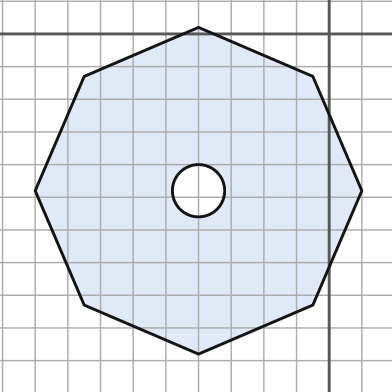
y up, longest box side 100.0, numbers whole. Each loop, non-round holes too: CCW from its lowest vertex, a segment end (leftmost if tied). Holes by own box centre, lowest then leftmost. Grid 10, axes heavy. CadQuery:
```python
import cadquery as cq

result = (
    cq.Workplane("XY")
    .moveTo(-40.0, -98.0)
    .lineTo(-5.0, -83.0)
    .lineTo(10.0, -48.0)
    .lineTo(-5.0, -13.0)
    .lineTo(-40.0, 2.0)
    .lineTo(-75.0, -13.0)
    .lineTo(-90.0, -48.0)
    .lineTo(-75.0, -83.0)
    .close()
    .moveTo(-40.0, -48.0)
    .circle(8.0)
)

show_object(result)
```